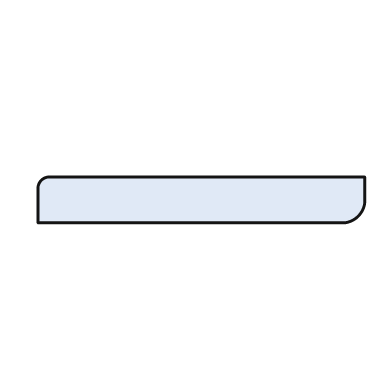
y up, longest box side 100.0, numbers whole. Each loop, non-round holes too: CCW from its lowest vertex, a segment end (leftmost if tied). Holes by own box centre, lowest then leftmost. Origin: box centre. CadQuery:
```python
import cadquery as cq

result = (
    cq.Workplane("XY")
    .moveTo(-50.0, -7.0)
    .lineTo(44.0, -7.0)
    .threePointArc((48.0, -5.0), (50.0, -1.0))
    .lineTo(50.0, 7.0)
    .lineTo(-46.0, 7.0)
    .threePointArc((-49.0, 6.0), (-50.0, 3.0))
    .close()
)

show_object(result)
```